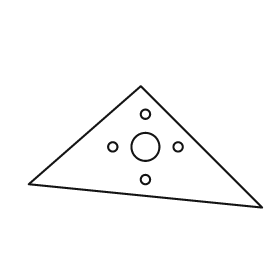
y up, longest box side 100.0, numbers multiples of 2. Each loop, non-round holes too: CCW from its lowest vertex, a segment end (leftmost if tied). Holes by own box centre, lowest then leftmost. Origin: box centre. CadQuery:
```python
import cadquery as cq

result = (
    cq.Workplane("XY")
    .moveTo(50.0, -26.0)
    .lineTo(-2.0, 26.0)
    .lineTo(-50.0, -16.0)
    .close()
    .moveTo(0.0, -14.0)
    .circle(2.0)
    .moveTo(-14.0, 0.0)
    .circle(2.0)
    .moveTo(0.0, 0.0)
    .circle(6.0)
    .moveTo(14.0, 0.0)
    .circle(2.0)
    .moveTo(0.0, 14.0)
    .circle(2.0)
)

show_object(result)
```